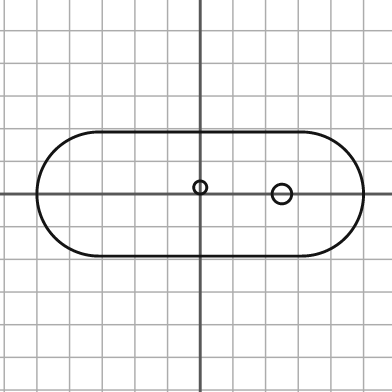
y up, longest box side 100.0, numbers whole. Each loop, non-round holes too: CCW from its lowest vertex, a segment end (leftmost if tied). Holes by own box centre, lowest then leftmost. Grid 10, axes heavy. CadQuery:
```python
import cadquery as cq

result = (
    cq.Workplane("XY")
    .moveTo(-31.0, -19.0)
    .lineTo(31.0, -19.0)
    .threePointArc((50.0, 0.0), (31.0, 19.0))
    .lineTo(-31.0, 19.0)
    .threePointArc((-50.0, 0.0), (-31.0, -19.0))
    .close()
    .moveTo(25.0, 0.0)
    .circle(3.0)
    .moveTo(0.0, 2.0)
    .circle(2.0)
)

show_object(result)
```